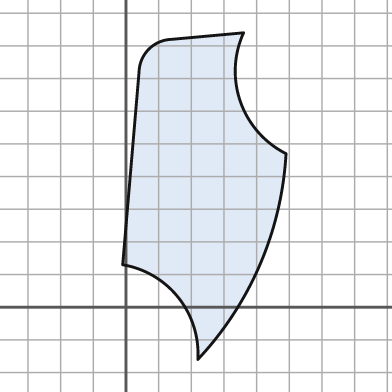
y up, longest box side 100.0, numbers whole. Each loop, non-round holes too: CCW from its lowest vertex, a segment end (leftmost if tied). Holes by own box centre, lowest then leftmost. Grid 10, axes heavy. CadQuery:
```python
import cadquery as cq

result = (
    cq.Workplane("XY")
    .moveTo(22.0, -16.0)
    .threePointArc((41.0, 13.0), (49.0, 47.0))
    .threePointArc((35.0, 63.0), (36.0, 84.0))
    .lineTo(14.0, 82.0)
    .threePointArc((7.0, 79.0), (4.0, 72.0))
    .lineTo(-1.0, 13.0)
    .threePointArc((16.0, 3.0), (22.0, -16.0))
    .close()
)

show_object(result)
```